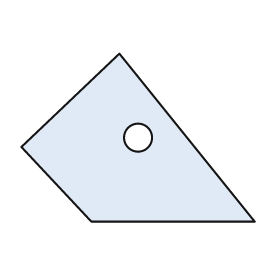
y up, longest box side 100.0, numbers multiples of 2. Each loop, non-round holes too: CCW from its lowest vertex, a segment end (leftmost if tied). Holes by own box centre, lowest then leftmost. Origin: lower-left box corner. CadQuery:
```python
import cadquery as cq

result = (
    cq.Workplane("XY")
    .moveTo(30.0, 0.0)
    .lineTo(100.0, 0.0)
    .lineTo(42.0, 72.0)
    .lineTo(0.0, 32.0)
    .close()
    .moveTo(50.0, 36.0)
    .circle(6.0)
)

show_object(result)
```